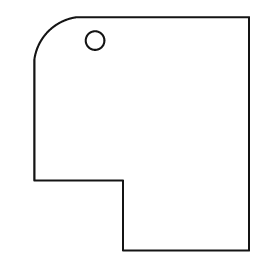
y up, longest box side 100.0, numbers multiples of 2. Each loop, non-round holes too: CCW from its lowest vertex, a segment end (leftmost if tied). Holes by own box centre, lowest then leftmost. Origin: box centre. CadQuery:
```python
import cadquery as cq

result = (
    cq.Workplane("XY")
    .moveTo(-8.0, -50.0)
    .lineTo(46.0, -50.0)
    .lineTo(46.0, 50.0)
    .lineTo(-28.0, 50.0)
    .threePointArc((-40.0, 44.0), (-46.0, 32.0))
    .lineTo(-46.0, -20.0)
    .lineTo(-8.0, -20.0)
    .close()
    .moveTo(-20.0, 40.0)
    .circle(4.0)
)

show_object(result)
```